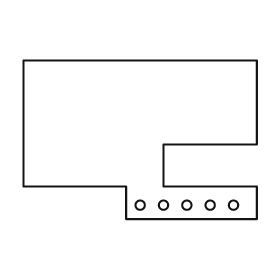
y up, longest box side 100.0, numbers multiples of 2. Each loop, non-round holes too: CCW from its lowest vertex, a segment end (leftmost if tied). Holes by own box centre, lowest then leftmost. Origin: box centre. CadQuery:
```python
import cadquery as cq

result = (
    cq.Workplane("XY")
    .moveTo(-6.0, -34.0)
    .lineTo(50.0, -34.0)
    .lineTo(50.0, -20.0)
    .lineTo(10.0, -20.0)
    .lineTo(10.0, -2.0)
    .lineTo(50.0, -2.0)
    .lineTo(50.0, 34.0)
    .lineTo(-50.0, 34.0)
    .lineTo(-50.0, -20.0)
    .lineTo(-6.0, -20.0)
    .close()
    .moveTo(0.0, -28.0)
    .circle(2.0)
    .moveTo(10.0, -28.0)
    .circle(2.0)
    .moveTo(20.0, -28.0)
    .circle(2.0)
    .moveTo(30.0, -28.0)
    .circle(2.0)
    .moveTo(40.0, -28.0)
    .circle(2.0)
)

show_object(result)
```